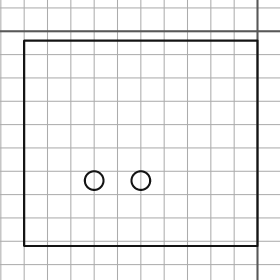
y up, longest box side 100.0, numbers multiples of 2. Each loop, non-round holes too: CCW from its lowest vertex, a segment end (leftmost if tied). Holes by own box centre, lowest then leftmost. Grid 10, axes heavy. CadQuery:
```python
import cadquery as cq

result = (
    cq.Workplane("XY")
    .moveTo(-100.0, -92.0)
    .lineTo(0.0, -92.0)
    .lineTo(0.0, -4.0)
    .lineTo(-100.0, -4.0)
    .close()
    .moveTo(-70.0, -64.0)
    .circle(4.0)
    .moveTo(-50.0, -64.0)
    .circle(4.0)
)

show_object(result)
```